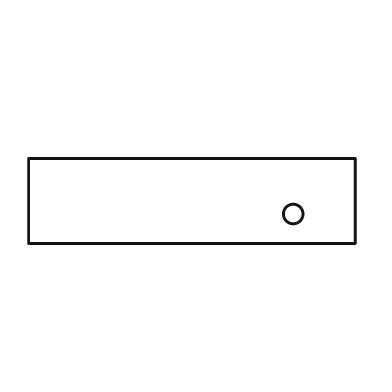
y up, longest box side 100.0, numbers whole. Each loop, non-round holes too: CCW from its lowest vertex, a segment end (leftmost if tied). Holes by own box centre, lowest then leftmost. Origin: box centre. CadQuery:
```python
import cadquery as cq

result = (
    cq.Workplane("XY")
    .moveTo(-50.0, -13.0)
    .lineTo(50.0, -13.0)
    .lineTo(50.0, 13.0)
    .lineTo(-50.0, 13.0)
    .close()
    .moveTo(31.0, -4.0)
    .circle(3.0)
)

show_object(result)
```